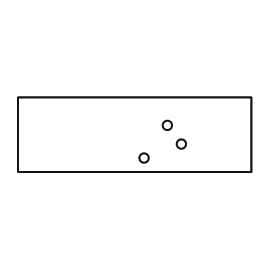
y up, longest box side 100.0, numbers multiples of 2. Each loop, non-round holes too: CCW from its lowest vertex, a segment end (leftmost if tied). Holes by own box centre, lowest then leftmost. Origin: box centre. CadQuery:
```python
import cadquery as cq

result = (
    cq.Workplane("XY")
    .moveTo(-50.0, -16.0)
    .lineTo(50.0, -16.0)
    .lineTo(50.0, 16.0)
    .lineTo(-50.0, 16.0)
    .close()
    .moveTo(4.0, -10.0)
    .circle(2.0)
    .moveTo(20.0, -4.0)
    .circle(2.0)
    .moveTo(14.0, 4.0)
    .circle(2.0)
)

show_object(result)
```